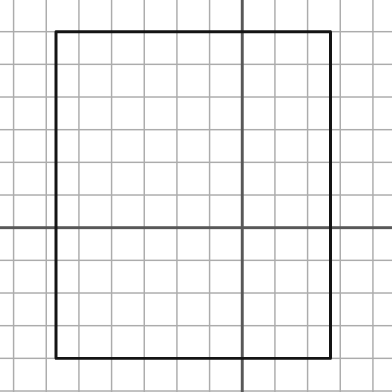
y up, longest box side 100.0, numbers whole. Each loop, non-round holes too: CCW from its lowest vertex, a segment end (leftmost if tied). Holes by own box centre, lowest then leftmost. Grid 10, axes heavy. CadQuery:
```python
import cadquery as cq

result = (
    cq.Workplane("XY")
    .moveTo(-57.0, -40.0)
    .lineTo(27.0, -40.0)
    .lineTo(27.0, 60.0)
    .lineTo(-57.0, 60.0)
    .close()
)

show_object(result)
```